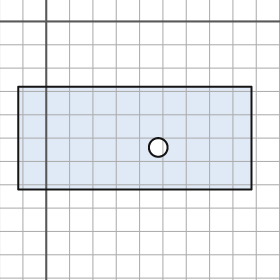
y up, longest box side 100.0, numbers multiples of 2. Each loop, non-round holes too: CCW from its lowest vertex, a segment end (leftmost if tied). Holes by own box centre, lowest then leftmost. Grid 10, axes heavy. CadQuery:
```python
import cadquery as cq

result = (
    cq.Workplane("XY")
    .moveTo(-12.0, -72.0)
    .lineTo(88.0, -72.0)
    .lineTo(88.0, -28.0)
    .lineTo(-12.0, -28.0)
    .close()
    .moveTo(48.0, -54.0)
    .circle(4.0)
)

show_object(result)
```